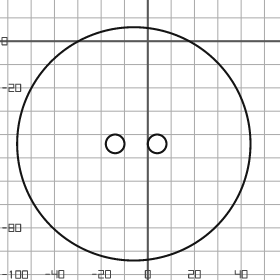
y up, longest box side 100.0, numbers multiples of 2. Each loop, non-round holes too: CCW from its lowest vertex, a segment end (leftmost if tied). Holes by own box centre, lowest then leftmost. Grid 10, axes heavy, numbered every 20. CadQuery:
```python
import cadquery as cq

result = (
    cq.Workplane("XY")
    .moveTo(-6.0, -44.0)
    .circle(50.0)
    .moveTo(-14.0, -44.0)
    .circle(4.0)
    .moveTo(4.0, -44.0)
    .circle(4.0)
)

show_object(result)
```